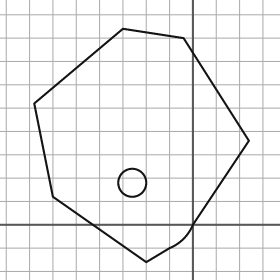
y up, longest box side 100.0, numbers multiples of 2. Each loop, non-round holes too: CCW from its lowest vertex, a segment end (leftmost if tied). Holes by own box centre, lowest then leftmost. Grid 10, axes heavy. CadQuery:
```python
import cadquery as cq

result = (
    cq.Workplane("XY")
    .moveTo(-20.0, -16.0)
    .lineTo(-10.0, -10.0)
    .threePointArc((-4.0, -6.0), (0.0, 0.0))
    .lineTo(24.0, 36.0)
    .lineTo(-4.0, 80.0)
    .lineTo(-30.0, 84.0)
    .lineTo(-68.0, 52.0)
    .lineTo(-60.0, 12.0)
    .close()
    .moveTo(-26.0, 18.0)
    .circle(6.0)
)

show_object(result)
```